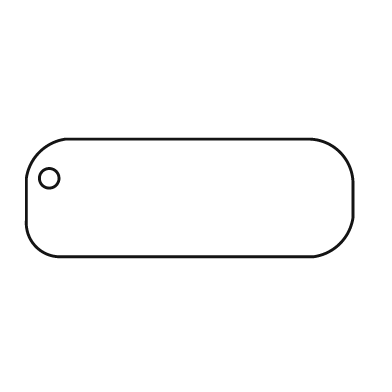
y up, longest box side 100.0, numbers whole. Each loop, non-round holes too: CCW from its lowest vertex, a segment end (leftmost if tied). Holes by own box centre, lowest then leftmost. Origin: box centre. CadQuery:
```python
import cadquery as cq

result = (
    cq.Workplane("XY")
    .moveTo(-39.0, -18.0)
    .lineTo(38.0, -18.0)
    .threePointArc((46.0, -14.0), (50.0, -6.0))
    .lineTo(50.0, 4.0)
    .threePointArc((46.0, 14.0), (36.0, 18.0))
    .lineTo(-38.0, 18.0)
    .threePointArc((-46.0, 14.0), (-50.0, 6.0))
    .lineTo(-50.0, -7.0)
    .threePointArc((-47.0, -15.0), (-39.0, -18.0))
    .close()
    .moveTo(-43.0, 6.0)
    .circle(3.0)
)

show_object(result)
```